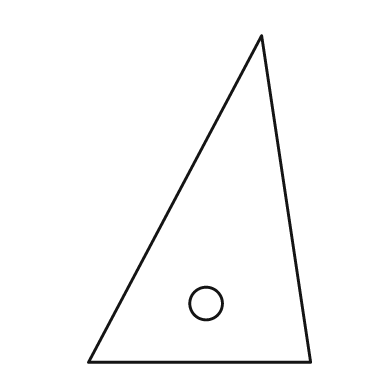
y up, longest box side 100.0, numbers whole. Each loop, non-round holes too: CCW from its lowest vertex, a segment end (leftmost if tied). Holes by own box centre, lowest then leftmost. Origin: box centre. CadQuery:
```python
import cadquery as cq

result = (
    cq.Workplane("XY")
    .moveTo(-34.0, -50.0)
    .lineTo(34.0, -50.0)
    .lineTo(19.0, 50.0)
    .close()
    .moveTo(2.0, -32.0)
    .circle(5.0)
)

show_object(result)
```